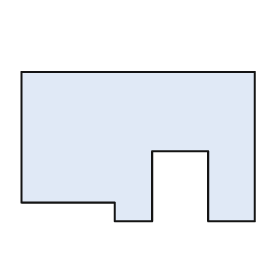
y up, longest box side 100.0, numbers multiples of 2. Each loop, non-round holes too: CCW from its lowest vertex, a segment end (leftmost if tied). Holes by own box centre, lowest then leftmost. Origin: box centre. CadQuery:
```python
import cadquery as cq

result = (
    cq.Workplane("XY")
    .moveTo(-10.0, -32.0)
    .lineTo(6.0, -32.0)
    .lineTo(6.0, -2.0)
    .lineTo(30.0, -2.0)
    .lineTo(30.0, -32.0)
    .lineTo(50.0, -32.0)
    .lineTo(50.0, 32.0)
    .lineTo(-50.0, 32.0)
    .lineTo(-50.0, -24.0)
    .lineTo(-10.0, -24.0)
    .close()
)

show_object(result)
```